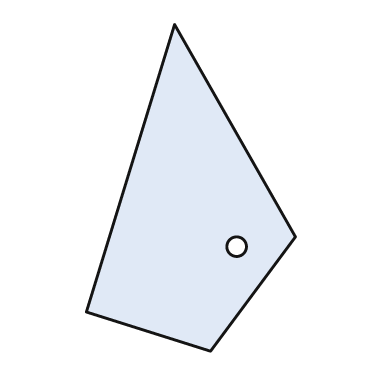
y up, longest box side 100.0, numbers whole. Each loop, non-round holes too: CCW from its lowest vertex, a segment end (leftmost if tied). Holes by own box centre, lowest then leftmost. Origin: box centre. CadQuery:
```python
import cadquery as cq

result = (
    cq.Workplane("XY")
    .moveTo(6.0, -50.0)
    .lineTo(32.0, -15.0)
    .lineTo(-5.0, 50.0)
    .lineTo(-32.0, -38.0)
    .close()
    .moveTo(14.0, -18.0)
    .circle(3.0)
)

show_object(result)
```